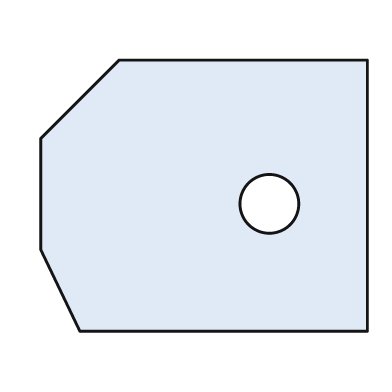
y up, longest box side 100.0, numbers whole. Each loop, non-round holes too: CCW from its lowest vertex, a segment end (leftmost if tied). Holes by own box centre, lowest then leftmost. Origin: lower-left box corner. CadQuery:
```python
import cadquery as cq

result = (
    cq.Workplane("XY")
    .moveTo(12.0, 0.0)
    .lineTo(100.0, 0.0)
    .lineTo(100.0, 83.0)
    .lineTo(24.0, 83.0)
    .lineTo(0.0, 59.0)
    .lineTo(0.0, 25.0)
    .close()
    .moveTo(70.0, 39.0)
    .circle(9.0)
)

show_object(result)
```